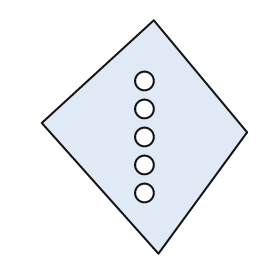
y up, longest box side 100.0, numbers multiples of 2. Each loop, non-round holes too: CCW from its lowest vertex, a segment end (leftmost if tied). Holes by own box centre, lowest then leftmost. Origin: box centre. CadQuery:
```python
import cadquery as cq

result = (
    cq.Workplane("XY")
    .moveTo(6.0, -50.0)
    .lineTo(44.0, 2.0)
    .lineTo(4.0, 50.0)
    .lineTo(-44.0, 6.0)
    .close()
    .moveTo(0.0, -24.0)
    .circle(4.0)
    .moveTo(0.0, -12.0)
    .circle(4.0)
    .moveTo(0.0, 0.0)
    .circle(4.0)
    .moveTo(0.0, 12.0)
    .circle(4.0)
    .moveTo(0.0, 24.0)
    .circle(4.0)
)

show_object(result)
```